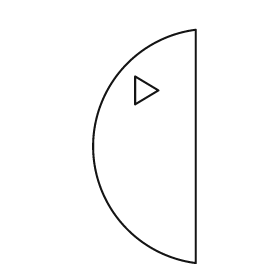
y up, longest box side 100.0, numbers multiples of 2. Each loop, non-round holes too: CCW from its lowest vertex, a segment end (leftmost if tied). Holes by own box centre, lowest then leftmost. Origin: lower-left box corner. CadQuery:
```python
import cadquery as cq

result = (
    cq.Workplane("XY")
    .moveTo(44.0, 0.0)
    .lineTo(44.0, 100.0)
    .threePointArc((0.0, 50.0), (44.0, 0.0))
    .close()
    .moveTo(18.0, 68.0)
    .lineTo(28.0, 74.0)
    .lineTo(18.0, 80.0)
    .close()
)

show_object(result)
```